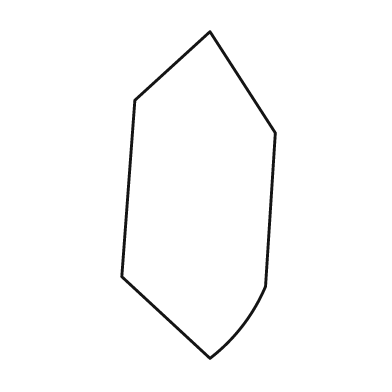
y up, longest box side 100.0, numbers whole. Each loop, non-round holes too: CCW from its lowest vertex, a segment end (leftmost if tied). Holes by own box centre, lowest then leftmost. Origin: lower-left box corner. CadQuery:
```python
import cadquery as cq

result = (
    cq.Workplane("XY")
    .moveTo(27.0, 0.0)
    .threePointArc((37.0, 10.0), (44.0, 22.0))
    .lineTo(47.0, 69.0)
    .lineTo(27.0, 100.0)
    .lineTo(4.0, 79.0)
    .lineTo(0.0, 25.0)
    .close()
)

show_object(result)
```